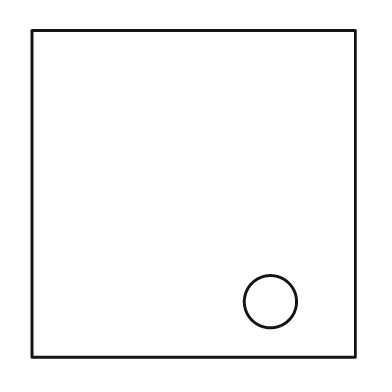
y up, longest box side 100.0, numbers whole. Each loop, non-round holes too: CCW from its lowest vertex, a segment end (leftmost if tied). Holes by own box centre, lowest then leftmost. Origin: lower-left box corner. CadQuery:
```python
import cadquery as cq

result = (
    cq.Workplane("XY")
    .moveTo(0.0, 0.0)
    .lineTo(99.0, 0.0)
    .lineTo(99.0, 100.0)
    .lineTo(0.0, 100.0)
    .close()
    .moveTo(73.0, 17.0)
    .circle(8.0)
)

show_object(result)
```